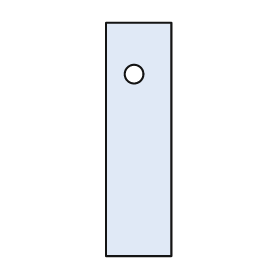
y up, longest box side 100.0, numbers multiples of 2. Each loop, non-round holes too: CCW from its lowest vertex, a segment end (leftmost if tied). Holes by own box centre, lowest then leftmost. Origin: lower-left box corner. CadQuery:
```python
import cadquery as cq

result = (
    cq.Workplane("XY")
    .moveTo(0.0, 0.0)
    .lineTo(28.0, 0.0)
    .lineTo(28.0, 100.0)
    .lineTo(0.0, 100.0)
    .close()
    .moveTo(12.0, 78.0)
    .circle(4.0)
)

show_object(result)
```